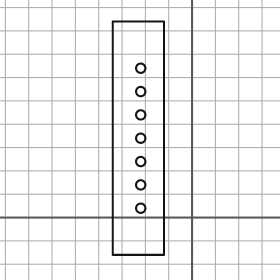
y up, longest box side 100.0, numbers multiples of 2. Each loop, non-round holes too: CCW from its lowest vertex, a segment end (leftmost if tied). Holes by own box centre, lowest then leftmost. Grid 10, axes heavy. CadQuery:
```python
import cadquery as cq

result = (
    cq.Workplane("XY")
    .moveTo(-34.0, -16.0)
    .lineTo(-12.0, -16.0)
    .lineTo(-12.0, 84.0)
    .lineTo(-34.0, 84.0)
    .close()
    .moveTo(-22.0, 4.0)
    .circle(2.0)
    .moveTo(-22.0, 14.0)
    .circle(2.0)
    .moveTo(-22.0, 24.0)
    .circle(2.0)
    .moveTo(-22.0, 34.0)
    .circle(2.0)
    .moveTo(-22.0, 44.0)
    .circle(2.0)
    .moveTo(-22.0, 54.0)
    .circle(2.0)
    .moveTo(-22.0, 64.0)
    .circle(2.0)
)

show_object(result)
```